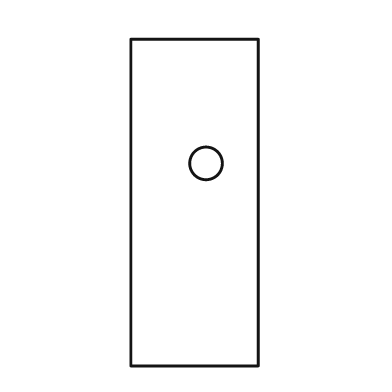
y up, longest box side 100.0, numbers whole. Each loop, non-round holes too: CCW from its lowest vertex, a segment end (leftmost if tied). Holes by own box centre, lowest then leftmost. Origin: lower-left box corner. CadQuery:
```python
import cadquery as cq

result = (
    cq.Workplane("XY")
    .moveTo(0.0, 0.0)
    .lineTo(39.0, 0.0)
    .lineTo(39.0, 100.0)
    .lineTo(0.0, 100.0)
    .close()
    .moveTo(23.0, 62.0)
    .circle(5.0)
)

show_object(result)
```